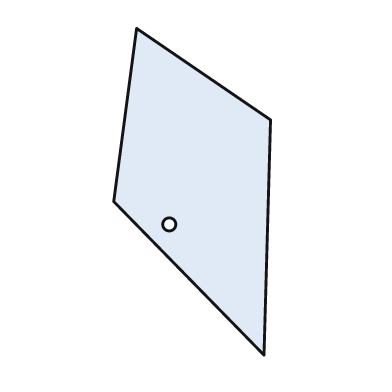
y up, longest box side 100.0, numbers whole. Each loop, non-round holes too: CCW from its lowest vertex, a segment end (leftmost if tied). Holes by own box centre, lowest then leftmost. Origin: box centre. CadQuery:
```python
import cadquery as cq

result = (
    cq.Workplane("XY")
    .moveTo(22.0, -50.0)
    .lineTo(24.0, 22.0)
    .lineTo(-17.0, 50.0)
    .lineTo(-24.0, -3.0)
    .close()
    .moveTo(-7.0, -10.0)
    .circle(2.0)
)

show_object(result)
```